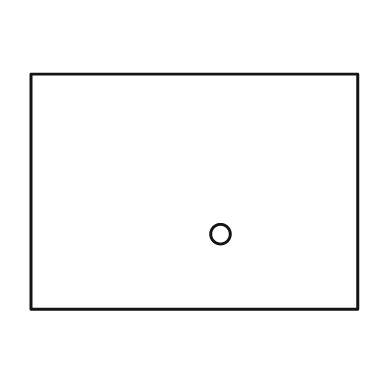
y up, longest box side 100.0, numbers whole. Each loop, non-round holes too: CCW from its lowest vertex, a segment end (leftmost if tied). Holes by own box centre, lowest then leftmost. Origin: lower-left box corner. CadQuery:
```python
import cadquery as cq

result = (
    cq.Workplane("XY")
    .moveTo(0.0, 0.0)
    .lineTo(100.0, 0.0)
    .lineTo(100.0, 72.0)
    .lineTo(0.0, 72.0)
    .close()
    .moveTo(58.0, 23.0)
    .circle(3.0)
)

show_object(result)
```